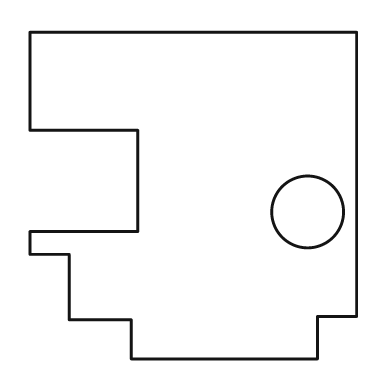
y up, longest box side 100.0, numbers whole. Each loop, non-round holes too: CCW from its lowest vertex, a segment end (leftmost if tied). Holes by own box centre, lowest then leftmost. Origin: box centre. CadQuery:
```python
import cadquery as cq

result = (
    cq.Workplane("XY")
    .moveTo(-19.0, -50.0)
    .lineTo(38.0, -50.0)
    .lineTo(38.0, -37.0)
    .lineTo(50.0, -37.0)
    .lineTo(50.0, 50.0)
    .lineTo(-50.0, 50.0)
    .lineTo(-50.0, 20.0)
    .lineTo(-17.0, 20.0)
    .lineTo(-17.0, -11.0)
    .lineTo(-50.0, -11.0)
    .lineTo(-50.0, -18.0)
    .lineTo(-38.0, -18.0)
    .lineTo(-38.0, -38.0)
    .lineTo(-19.0, -38.0)
    .close()
    .moveTo(35.0, -5.0)
    .circle(11.0)
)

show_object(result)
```